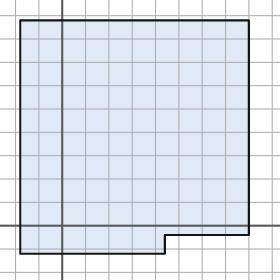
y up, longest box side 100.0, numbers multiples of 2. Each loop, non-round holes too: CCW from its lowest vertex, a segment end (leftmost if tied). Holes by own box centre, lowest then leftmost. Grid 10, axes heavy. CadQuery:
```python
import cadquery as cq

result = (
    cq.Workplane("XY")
    .moveTo(-18.0, -12.0)
    .lineTo(44.0, -12.0)
    .lineTo(44.0, -4.0)
    .lineTo(80.0, -4.0)
    .lineTo(80.0, 88.0)
    .lineTo(-18.0, 88.0)
    .close()
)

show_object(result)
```